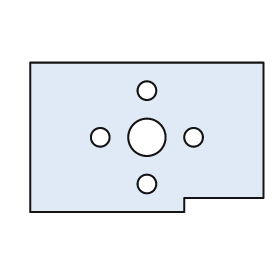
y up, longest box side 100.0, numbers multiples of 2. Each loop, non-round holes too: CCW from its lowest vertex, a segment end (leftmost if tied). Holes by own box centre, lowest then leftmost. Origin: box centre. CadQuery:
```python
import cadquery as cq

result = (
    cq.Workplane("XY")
    .moveTo(-50.0, -32.0)
    .lineTo(16.0, -32.0)
    .lineTo(16.0, -26.0)
    .lineTo(50.0, -26.0)
    .lineTo(50.0, 32.0)
    .lineTo(-50.0, 32.0)
    .close()
    .moveTo(0.0, -20.0)
    .circle(4.0)
    .moveTo(-20.0, 0.0)
    .circle(4.0)
    .moveTo(0.0, 0.0)
    .circle(8.0)
    .moveTo(20.0, 0.0)
    .circle(4.0)
    .moveTo(0.0, 20.0)
    .circle(4.0)
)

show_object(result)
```